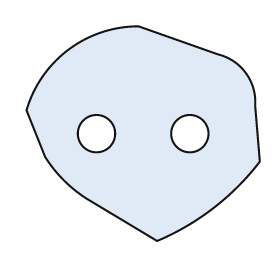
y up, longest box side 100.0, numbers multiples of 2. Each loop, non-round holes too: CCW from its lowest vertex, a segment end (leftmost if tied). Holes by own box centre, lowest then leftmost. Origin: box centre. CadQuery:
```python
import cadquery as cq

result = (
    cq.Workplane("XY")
    .moveTo(6.0, -46.0)
    .threePointArc((30.0, -32.0), (50.0, -12.0))
    .lineTo(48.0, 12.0)
    .threePointArc((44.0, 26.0), (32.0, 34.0))
    .lineTo(-2.0, 46.0)
    .threePointArc((-32.0, 36.0), (-50.0, 10.0))
    .lineTo(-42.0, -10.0)
    .threePointArc((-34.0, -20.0), (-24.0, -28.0))
    .close()
    .moveTo(-20.0, 0.0)
    .circle(8.0)
    .moveTo(20.0, 0.0)
    .circle(8.0)
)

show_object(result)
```